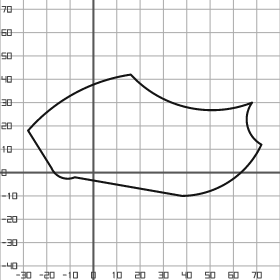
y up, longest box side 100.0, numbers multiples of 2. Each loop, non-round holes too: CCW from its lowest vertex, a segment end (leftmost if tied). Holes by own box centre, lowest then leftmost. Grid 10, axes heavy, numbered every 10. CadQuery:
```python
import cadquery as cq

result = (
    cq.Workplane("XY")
    .moveTo(38.0, -10.0)
    .threePointArc((58.0, -4.0), (72.0, 12.0))
    .threePointArc((66.0, 20.0), (68.0, 30.0))
    .threePointArc((40.0, 28.0), (16.0, 42.0))
    .threePointArc((-8.0, 34.0), (-28.0, 18.0))
    .lineTo(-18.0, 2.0)
    .threePointArc((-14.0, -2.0), (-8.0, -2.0))
    .close()
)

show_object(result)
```